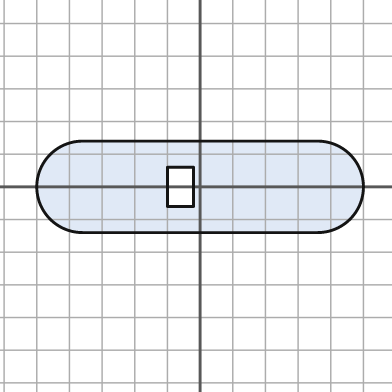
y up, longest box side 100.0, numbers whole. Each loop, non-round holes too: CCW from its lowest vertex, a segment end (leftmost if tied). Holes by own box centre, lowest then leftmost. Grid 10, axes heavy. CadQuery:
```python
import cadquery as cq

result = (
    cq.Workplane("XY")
    .moveTo(-36.0, -14.0)
    .lineTo(36.0, -14.0)
    .threePointArc((50.0, 0.0), (36.0, 14.0))
    .lineTo(-36.0, 14.0)
    .threePointArc((-50.0, 0.0), (-36.0, -14.0))
    .close()
    .moveTo(-10.0, -6.0)
    .lineTo(-2.0, -6.0)
    .lineTo(-2.0, 6.0)
    .lineTo(-10.0, 6.0)
    .close()
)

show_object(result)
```